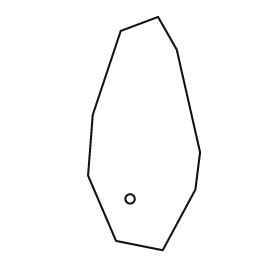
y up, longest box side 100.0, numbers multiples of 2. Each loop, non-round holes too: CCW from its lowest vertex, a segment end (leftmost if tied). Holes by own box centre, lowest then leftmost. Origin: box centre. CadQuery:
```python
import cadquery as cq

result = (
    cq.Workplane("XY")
    .moveTo(8.0, -50.0)
    .lineTo(22.0, -24.0)
    .lineTo(24.0, -8.0)
    .lineTo(14.0, 36.0)
    .lineTo(6.0, 50.0)
    .lineTo(-10.0, 44.0)
    .lineTo(-22.0, 8.0)
    .lineTo(-24.0, -18.0)
    .lineTo(-12.0, -46.0)
    .close()
    .moveTo(-6.0, -28.0)
    .circle(2.0)
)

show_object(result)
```